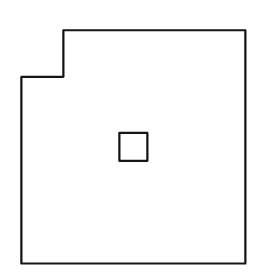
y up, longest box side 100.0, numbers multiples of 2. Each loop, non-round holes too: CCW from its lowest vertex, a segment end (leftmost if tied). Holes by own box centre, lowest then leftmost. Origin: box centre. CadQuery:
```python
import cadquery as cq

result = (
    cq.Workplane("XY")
    .moveTo(-48.0, -50.0)
    .lineTo(48.0, -50.0)
    .lineTo(48.0, 50.0)
    .lineTo(-30.0, 50.0)
    .lineTo(-30.0, 30.0)
    .lineTo(-48.0, 30.0)
    .close()
    .moveTo(-6.0, -6.0)
    .lineTo(6.0, -6.0)
    .lineTo(6.0, 6.0)
    .lineTo(-6.0, 6.0)
    .close()
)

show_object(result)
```